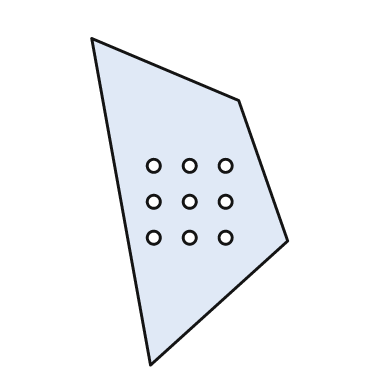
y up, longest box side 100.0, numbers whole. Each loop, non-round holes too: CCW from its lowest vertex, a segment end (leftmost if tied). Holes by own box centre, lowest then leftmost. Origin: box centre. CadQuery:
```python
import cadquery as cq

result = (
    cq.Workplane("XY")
    .moveTo(-12.0, -50.0)
    .lineTo(30.0, -12.0)
    .lineTo(15.0, 31.0)
    .lineTo(-30.0, 50.0)
    .close()
    .moveTo(-11.0, -11.0)
    .circle(2.0)
    .moveTo(0.0, -11.0)
    .circle(2.0)
    .moveTo(11.0, -11.0)
    .circle(2.0)
    .moveTo(-11.0, 0.0)
    .circle(2.0)
    .moveTo(0.0, 0.0)
    .circle(2.0)
    .moveTo(11.0, 0.0)
    .circle(2.0)
    .moveTo(-11.0, 11.0)
    .circle(2.0)
    .moveTo(0.0, 11.0)
    .circle(2.0)
    .moveTo(11.0, 11.0)
    .circle(2.0)
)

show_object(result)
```